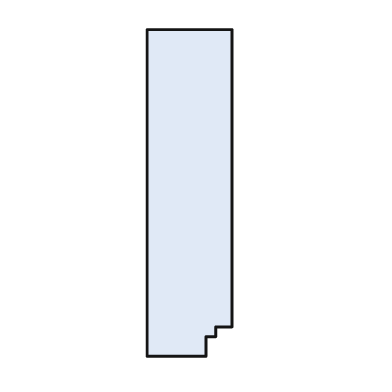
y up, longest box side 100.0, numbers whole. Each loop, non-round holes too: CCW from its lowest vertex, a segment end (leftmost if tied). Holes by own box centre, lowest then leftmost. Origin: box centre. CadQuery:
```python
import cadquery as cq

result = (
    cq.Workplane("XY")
    .moveTo(-13.0, -50.0)
    .lineTo(5.0, -50.0)
    .lineTo(5.0, -44.0)
    .lineTo(8.0, -44.0)
    .lineTo(8.0, -41.0)
    .lineTo(13.0, -41.0)
    .lineTo(13.0, 50.0)
    .lineTo(-13.0, 50.0)
    .close()
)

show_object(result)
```